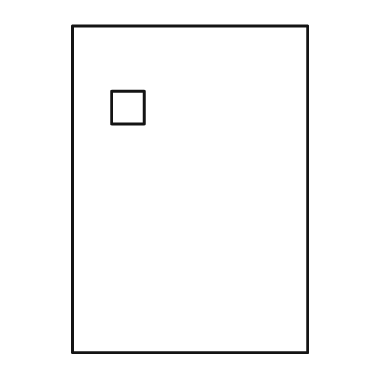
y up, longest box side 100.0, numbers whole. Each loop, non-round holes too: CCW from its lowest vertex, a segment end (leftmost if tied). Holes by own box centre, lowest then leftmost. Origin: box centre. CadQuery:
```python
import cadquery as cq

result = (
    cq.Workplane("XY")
    .moveTo(-36.0, -50.0)
    .lineTo(36.0, -50.0)
    .lineTo(36.0, 50.0)
    .lineTo(-36.0, 50.0)
    .close()
    .moveTo(-24.0, 20.0)
    .lineTo(-14.0, 20.0)
    .lineTo(-14.0, 30.0)
    .lineTo(-24.0, 30.0)
    .close()
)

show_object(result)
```